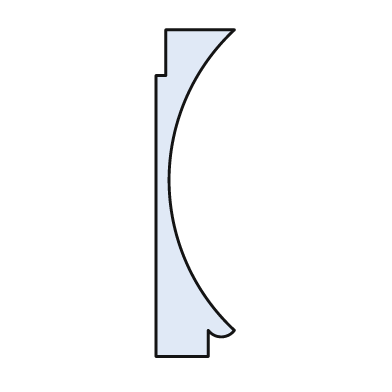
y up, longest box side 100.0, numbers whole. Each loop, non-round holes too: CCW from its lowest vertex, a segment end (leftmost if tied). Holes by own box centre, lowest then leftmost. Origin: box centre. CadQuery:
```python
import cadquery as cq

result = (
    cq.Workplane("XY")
    .moveTo(-12.0, -50.0)
    .lineTo(4.0, -50.0)
    .lineTo(4.0, -42.0)
    .threePointArc((8.0, -44.0), (12.0, -42.0))
    .threePointArc((-8.0, 4.0), (12.0, 50.0))
    .lineTo(-9.0, 50.0)
    .lineTo(-9.0, 36.0)
    .lineTo(-12.0, 36.0)
    .close()
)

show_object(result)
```